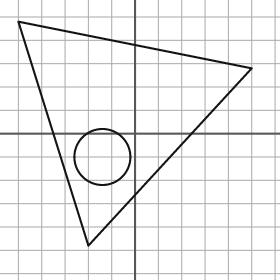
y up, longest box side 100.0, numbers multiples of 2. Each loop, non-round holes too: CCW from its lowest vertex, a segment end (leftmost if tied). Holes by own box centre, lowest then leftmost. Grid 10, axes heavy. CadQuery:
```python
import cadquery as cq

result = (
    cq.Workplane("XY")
    .moveTo(-20.0, -48.0)
    .lineTo(50.0, 28.0)
    .lineTo(-50.0, 48.0)
    .close()
    .moveTo(-14.0, -10.0)
    .circle(12.0)
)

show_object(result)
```